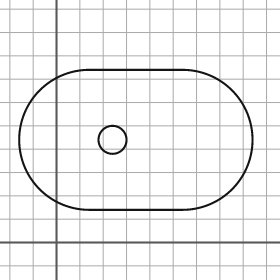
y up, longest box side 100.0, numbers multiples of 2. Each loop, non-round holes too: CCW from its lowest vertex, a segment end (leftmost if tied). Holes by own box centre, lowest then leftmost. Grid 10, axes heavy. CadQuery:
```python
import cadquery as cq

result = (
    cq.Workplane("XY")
    .moveTo(14.0, 14.0)
    .lineTo(54.0, 14.0)
    .threePointArc((84.0, 44.0), (54.0, 74.0))
    .lineTo(14.0, 74.0)
    .threePointArc((-16.0, 44.0), (14.0, 14.0))
    .close()
    .moveTo(24.0, 44.0)
    .circle(6.0)
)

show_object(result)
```